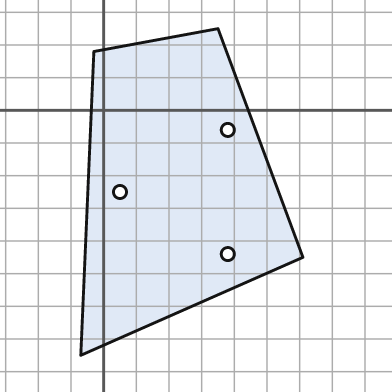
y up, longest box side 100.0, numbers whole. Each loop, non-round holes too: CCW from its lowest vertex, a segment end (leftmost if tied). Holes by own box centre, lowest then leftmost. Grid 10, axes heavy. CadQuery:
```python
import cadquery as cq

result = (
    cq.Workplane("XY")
    .moveTo(-7.0, -75.0)
    .lineTo(61.0, -45.0)
    .lineTo(35.0, 25.0)
    .lineTo(-3.0, 18.0)
    .close()
    .moveTo(38.0, -44.0)
    .circle(2.0)
    .moveTo(5.0, -25.0)
    .circle(2.0)
    .moveTo(38.0, -6.0)
    .circle(2.0)
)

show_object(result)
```